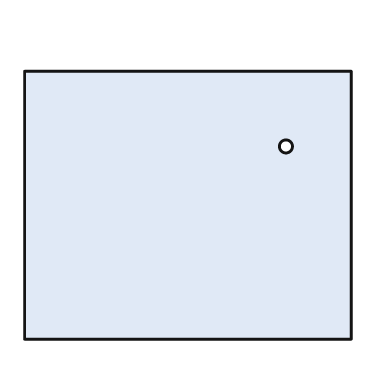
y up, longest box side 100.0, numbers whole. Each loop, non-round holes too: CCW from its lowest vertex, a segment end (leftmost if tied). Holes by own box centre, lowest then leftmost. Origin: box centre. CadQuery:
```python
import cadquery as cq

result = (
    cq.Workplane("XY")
    .moveTo(-50.0, -41.0)
    .lineTo(50.0, -41.0)
    .lineTo(50.0, 41.0)
    .lineTo(-50.0, 41.0)
    .close()
    .moveTo(30.0, 18.0)
    .circle(2.0)
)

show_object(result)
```